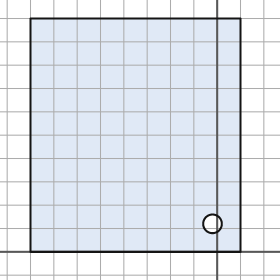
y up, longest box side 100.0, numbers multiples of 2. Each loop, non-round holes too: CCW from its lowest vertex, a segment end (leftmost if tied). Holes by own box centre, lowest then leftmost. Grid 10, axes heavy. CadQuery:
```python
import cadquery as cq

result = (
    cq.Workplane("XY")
    .moveTo(-80.0, 0.0)
    .lineTo(10.0, 0.0)
    .lineTo(10.0, 100.0)
    .lineTo(-80.0, 100.0)
    .close()
    .moveTo(-2.0, 12.0)
    .circle(4.0)
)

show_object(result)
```